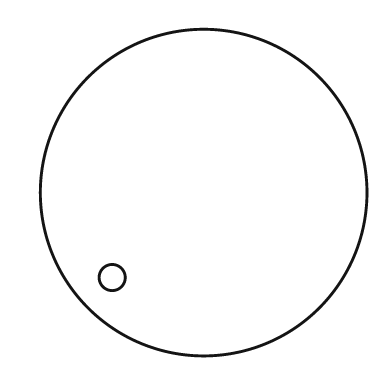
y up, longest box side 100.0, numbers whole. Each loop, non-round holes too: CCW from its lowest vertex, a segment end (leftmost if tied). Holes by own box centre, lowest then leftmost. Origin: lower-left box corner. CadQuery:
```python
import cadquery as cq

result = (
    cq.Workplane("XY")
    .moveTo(50.0, 50.0)
    .circle(50.0)
    .moveTo(22.0, 24.0)
    .circle(4.0)
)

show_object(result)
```